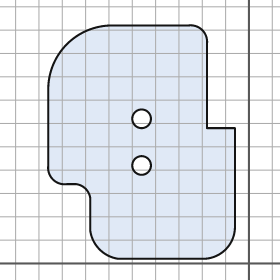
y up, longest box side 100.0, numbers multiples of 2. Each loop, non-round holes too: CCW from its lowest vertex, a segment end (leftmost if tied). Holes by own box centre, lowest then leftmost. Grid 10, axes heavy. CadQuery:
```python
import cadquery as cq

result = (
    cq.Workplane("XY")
    .moveTo(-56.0, 2.0)
    .lineTo(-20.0, 2.0)
    .threePointArc((-10.0, 6.0), (-6.0, 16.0))
    .lineTo(-6.0, 58.0)
    .lineTo(-18.0, 58.0)
    .lineTo(-18.0, 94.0)
    .threePointArc((-20.0, 100.0), (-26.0, 102.0))
    .lineTo(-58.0, 102.0)
    .threePointArc((-78.0, 94.0), (-86.0, 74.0))
    .lineTo(-86.0, 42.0)
    .threePointArc((-84.0, 36.0), (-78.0, 34.0))
    .lineTo(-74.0, 34.0)
    .threePointArc((-70.0, 32.0), (-68.0, 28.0))
    .lineTo(-68.0, 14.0)
    .threePointArc((-64.0, 6.0), (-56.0, 2.0))
    .close()
    .moveTo(-46.0, 42.0)
    .circle(4.0)
    .moveTo(-46.0, 62.0)
    .circle(4.0)
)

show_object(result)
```